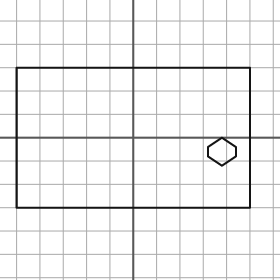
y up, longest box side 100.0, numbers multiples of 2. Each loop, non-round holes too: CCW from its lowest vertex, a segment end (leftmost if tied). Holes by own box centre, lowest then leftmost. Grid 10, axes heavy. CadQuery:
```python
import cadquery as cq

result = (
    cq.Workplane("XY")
    .moveTo(-50.0, -30.0)
    .lineTo(50.0, -30.0)
    .lineTo(50.0, 30.0)
    .lineTo(-50.0, 30.0)
    .close()
    .moveTo(38.0, -12.0)
    .lineTo(44.0, -8.0)
    .lineTo(44.0, -4.0)
    .lineTo(38.0, 0.0)
    .lineTo(32.0, -4.0)
    .lineTo(32.0, -8.0)
    .close()
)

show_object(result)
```